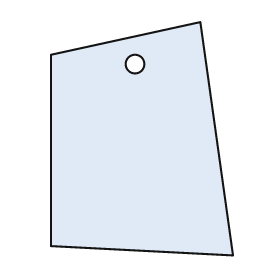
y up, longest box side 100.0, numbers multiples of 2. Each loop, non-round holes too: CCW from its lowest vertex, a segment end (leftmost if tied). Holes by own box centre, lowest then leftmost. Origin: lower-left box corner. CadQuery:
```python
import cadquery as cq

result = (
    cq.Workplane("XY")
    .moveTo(78.0, 0.0)
    .lineTo(64.0, 100.0)
    .lineTo(0.0, 86.0)
    .lineTo(0.0, 4.0)
    .close()
    .moveTo(36.0, 82.0)
    .circle(4.0)
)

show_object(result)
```